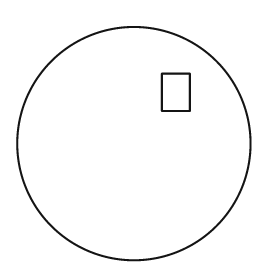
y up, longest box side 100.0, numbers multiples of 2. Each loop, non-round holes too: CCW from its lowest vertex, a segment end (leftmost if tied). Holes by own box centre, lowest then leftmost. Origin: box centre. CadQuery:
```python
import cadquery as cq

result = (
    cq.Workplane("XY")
    .moveTo(0.0, 0.0)
    .circle(50.0)
    .moveTo(12.0, 14.0)
    .lineTo(24.0, 14.0)
    .lineTo(24.0, 30.0)
    .lineTo(12.0, 30.0)
    .close()
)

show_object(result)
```